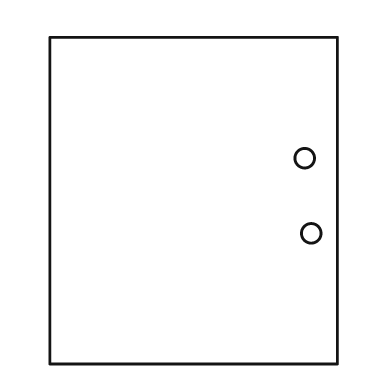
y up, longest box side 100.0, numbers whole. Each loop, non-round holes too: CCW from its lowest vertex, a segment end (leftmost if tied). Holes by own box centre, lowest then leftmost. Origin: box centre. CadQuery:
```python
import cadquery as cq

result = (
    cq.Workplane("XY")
    .moveTo(-44.0, -50.0)
    .lineTo(44.0, -50.0)
    .lineTo(44.0, 50.0)
    .lineTo(-44.0, 50.0)
    .close()
    .moveTo(36.0, -10.0)
    .circle(3.0)
    .moveTo(34.0, 13.0)
    .circle(3.0)
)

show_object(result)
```